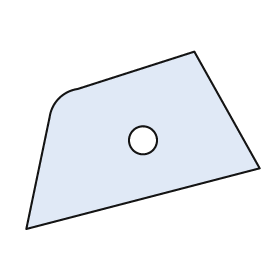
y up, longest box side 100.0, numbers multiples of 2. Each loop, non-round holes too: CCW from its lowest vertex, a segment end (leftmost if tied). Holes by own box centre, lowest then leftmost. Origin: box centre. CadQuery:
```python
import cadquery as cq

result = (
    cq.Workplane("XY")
    .moveTo(-50.0, -38.0)
    .lineTo(50.0, -12.0)
    .lineTo(22.0, 38.0)
    .lineTo(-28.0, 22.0)
    .threePointArc((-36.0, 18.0), (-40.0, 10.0))
    .close()
    .moveTo(0.0, 0.0)
    .circle(6.0)
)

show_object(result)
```